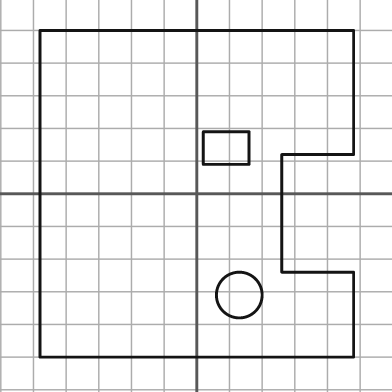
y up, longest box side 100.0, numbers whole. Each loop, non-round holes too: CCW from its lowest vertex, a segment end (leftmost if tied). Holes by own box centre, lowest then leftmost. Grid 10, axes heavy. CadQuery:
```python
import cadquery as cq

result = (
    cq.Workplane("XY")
    .moveTo(-48.0, -50.0)
    .lineTo(48.0, -50.0)
    .lineTo(48.0, -24.0)
    .lineTo(26.0, -24.0)
    .lineTo(26.0, 12.0)
    .lineTo(48.0, 12.0)
    .lineTo(48.0, 50.0)
    .lineTo(-48.0, 50.0)
    .close()
    .moveTo(13.0, -31.0)
    .circle(7.0)
    .moveTo(2.0, 9.0)
    .lineTo(16.0, 9.0)
    .lineTo(16.0, 19.0)
    .lineTo(2.0, 19.0)
    .close()
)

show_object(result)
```